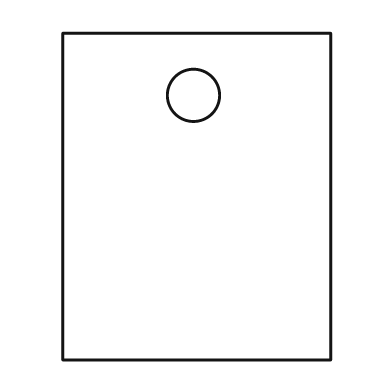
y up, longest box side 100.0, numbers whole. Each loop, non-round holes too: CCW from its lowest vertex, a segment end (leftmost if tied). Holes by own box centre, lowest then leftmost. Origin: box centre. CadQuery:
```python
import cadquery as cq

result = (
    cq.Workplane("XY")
    .moveTo(-41.0, -50.0)
    .lineTo(41.0, -50.0)
    .lineTo(41.0, 50.0)
    .lineTo(-41.0, 50.0)
    .close()
    .moveTo(-1.0, 31.0)
    .circle(8.0)
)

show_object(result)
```